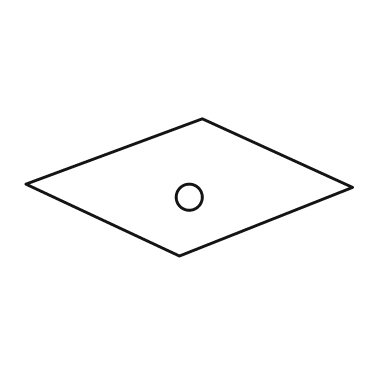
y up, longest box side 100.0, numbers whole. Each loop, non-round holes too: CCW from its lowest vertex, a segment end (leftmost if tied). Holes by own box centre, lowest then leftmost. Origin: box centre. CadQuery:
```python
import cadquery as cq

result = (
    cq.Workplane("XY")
    .moveTo(-3.0, -21.0)
    .lineTo(50.0, 0.0)
    .lineTo(4.0, 21.0)
    .lineTo(-50.0, 1.0)
    .close()
    .moveTo(0.0, -3.0)
    .circle(4.0)
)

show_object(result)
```